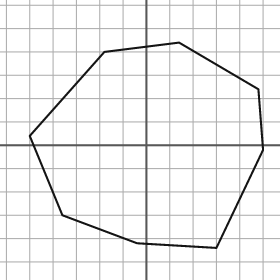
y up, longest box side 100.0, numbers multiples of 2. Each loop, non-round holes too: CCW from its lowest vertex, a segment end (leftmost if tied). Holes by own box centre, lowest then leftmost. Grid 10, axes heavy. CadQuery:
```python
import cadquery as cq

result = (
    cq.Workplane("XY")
    .moveTo(30.0, -44.0)
    .lineTo(50.0, -2.0)
    .lineTo(48.0, 24.0)
    .lineTo(14.0, 44.0)
    .lineTo(-18.0, 40.0)
    .lineTo(-50.0, 4.0)
    .lineTo(-36.0, -30.0)
    .lineTo(-4.0, -42.0)
    .close()
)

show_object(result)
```